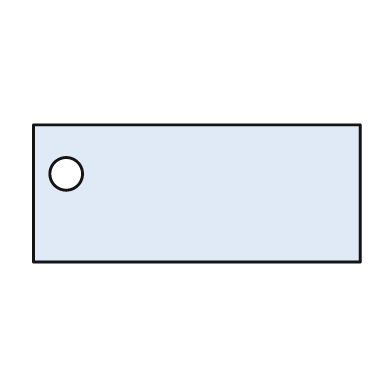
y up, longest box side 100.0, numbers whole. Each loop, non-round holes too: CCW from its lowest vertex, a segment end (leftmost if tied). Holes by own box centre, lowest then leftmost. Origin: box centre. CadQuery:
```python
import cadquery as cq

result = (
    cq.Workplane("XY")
    .moveTo(-50.0, -21.0)
    .lineTo(50.0, -21.0)
    .lineTo(50.0, 21.0)
    .lineTo(-50.0, 21.0)
    .close()
    .moveTo(-40.0, 6.0)
    .circle(5.0)
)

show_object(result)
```